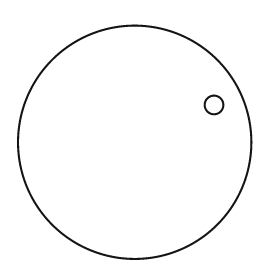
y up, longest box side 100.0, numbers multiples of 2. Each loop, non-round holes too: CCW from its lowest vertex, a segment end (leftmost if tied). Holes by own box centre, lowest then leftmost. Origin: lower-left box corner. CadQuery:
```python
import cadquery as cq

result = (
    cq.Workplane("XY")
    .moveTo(50.0, 50.0)
    .circle(50.0)
    .moveTo(84.0, 66.0)
    .circle(4.0)
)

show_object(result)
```